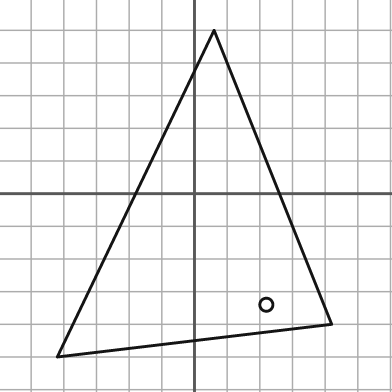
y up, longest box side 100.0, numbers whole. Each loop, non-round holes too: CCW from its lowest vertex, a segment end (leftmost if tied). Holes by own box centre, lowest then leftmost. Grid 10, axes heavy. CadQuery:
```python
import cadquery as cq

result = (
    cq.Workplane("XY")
    .moveTo(-42.0, -50.0)
    .lineTo(42.0, -40.0)
    .lineTo(6.0, 50.0)
    .close()
    .moveTo(22.0, -34.0)
    .circle(2.0)
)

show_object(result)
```